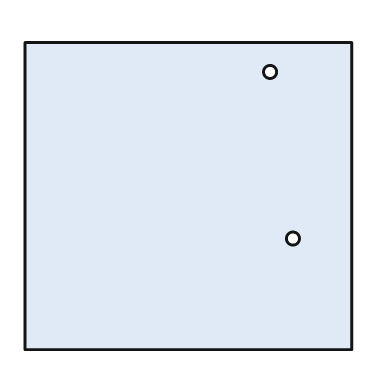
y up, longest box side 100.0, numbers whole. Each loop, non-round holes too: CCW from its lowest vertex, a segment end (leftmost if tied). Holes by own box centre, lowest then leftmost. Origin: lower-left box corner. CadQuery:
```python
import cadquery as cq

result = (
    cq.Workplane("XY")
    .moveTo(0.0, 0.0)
    .lineTo(100.0, 0.0)
    .lineTo(100.0, 94.0)
    .lineTo(0.0, 94.0)
    .close()
    .moveTo(82.0, 34.0)
    .circle(2.0)
    .moveTo(75.0, 85.0)
    .circle(2.0)
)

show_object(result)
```